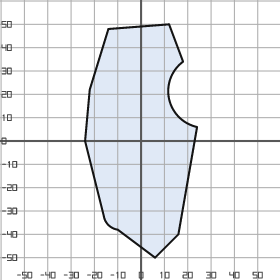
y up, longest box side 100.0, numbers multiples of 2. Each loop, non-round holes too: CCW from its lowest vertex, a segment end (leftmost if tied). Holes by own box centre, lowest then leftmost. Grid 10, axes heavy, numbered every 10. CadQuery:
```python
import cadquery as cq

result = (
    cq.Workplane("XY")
    .moveTo(6.0, -50.0)
    .lineTo(16.0, -40.0)
    .lineTo(24.0, 6.0)
    .threePointArc((12.0, 18.0), (18.0, 34.0))
    .lineTo(12.0, 50.0)
    .lineTo(-14.0, 48.0)
    .lineTo(-22.0, 22.0)
    .lineTo(-24.0, 0.0)
    .lineTo(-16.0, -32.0)
    .threePointArc((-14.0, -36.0), (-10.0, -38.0))
    .close()
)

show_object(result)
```